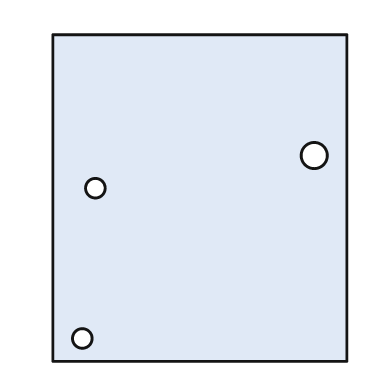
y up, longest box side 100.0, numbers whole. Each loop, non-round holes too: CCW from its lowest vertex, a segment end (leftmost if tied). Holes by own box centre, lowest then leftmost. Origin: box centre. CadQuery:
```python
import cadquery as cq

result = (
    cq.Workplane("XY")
    .moveTo(-45.0, -50.0)
    .lineTo(45.0, -50.0)
    .lineTo(45.0, 50.0)
    .lineTo(-45.0, 50.0)
    .close()
    .moveTo(-36.0, -43.0)
    .circle(3.0)
    .moveTo(-32.0, 3.0)
    .circle(3.0)
    .moveTo(35.0, 13.0)
    .circle(4.0)
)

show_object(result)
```